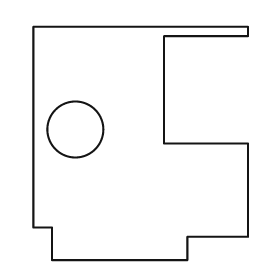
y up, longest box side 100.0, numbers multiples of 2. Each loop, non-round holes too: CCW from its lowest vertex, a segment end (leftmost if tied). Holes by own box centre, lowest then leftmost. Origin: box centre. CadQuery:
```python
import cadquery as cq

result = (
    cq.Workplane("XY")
    .moveTo(-38.0, -50.0)
    .lineTo(20.0, -50.0)
    .lineTo(20.0, -40.0)
    .lineTo(46.0, -40.0)
    .lineTo(46.0, 0.0)
    .lineTo(10.0, 0.0)
    .lineTo(10.0, 46.0)
    .lineTo(46.0, 46.0)
    .lineTo(46.0, 50.0)
    .lineTo(-46.0, 50.0)
    .lineTo(-46.0, -36.0)
    .lineTo(-38.0, -36.0)
    .close()
    .moveTo(-28.0, 6.0)
    .circle(12.0)
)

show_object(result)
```